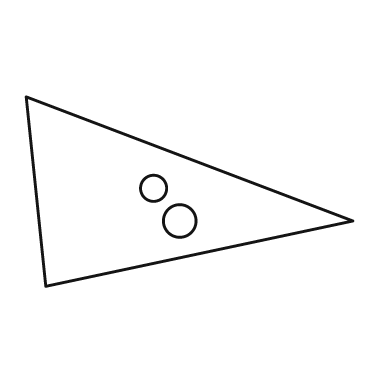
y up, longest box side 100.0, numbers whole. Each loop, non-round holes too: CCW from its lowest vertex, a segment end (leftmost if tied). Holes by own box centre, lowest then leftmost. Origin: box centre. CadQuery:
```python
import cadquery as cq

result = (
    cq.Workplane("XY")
    .moveTo(-44.0, -29.0)
    .lineTo(50.0, -9.0)
    .lineTo(-50.0, 29.0)
    .close()
    .moveTo(-3.0, -9.0)
    .circle(5.0)
    .moveTo(-11.0, 1.0)
    .circle(4.0)
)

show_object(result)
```